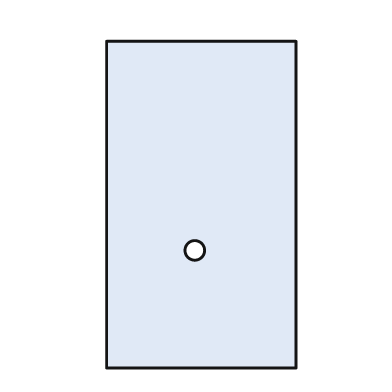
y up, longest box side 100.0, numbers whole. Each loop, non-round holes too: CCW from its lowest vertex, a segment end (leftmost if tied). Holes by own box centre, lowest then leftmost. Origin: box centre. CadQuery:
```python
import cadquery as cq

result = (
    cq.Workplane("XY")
    .moveTo(-29.0, -50.0)
    .lineTo(29.0, -50.0)
    .lineTo(29.0, 50.0)
    .lineTo(-29.0, 50.0)
    .close()
    .moveTo(-2.0, -14.0)
    .circle(3.0)
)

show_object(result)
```